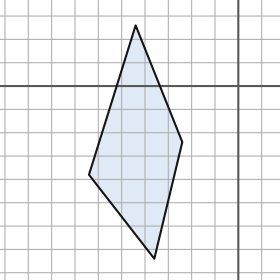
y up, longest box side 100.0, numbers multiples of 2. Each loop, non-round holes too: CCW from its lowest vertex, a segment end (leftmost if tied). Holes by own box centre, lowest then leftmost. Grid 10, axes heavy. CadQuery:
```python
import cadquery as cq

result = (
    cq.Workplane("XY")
    .moveTo(-36.0, -74.0)
    .lineTo(-24.0, -24.0)
    .lineTo(-44.0, 26.0)
    .lineTo(-64.0, -38.0)
    .close()
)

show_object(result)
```